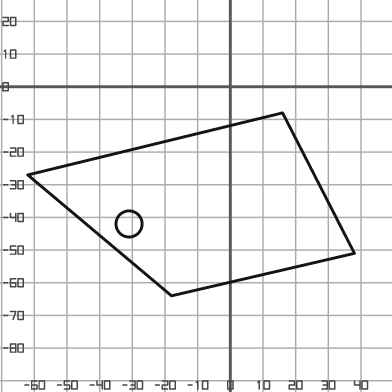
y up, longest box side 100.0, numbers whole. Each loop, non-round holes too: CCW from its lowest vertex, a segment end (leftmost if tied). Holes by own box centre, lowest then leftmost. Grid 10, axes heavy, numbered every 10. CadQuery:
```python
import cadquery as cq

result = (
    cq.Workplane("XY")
    .moveTo(-18.0, -64.0)
    .lineTo(38.0, -51.0)
    .lineTo(16.0, -8.0)
    .lineTo(-62.0, -27.0)
    .close()
    .moveTo(-31.0, -42.0)
    .circle(4.0)
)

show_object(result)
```